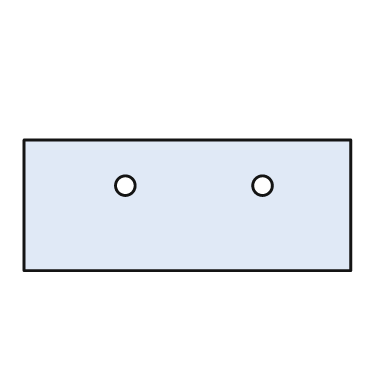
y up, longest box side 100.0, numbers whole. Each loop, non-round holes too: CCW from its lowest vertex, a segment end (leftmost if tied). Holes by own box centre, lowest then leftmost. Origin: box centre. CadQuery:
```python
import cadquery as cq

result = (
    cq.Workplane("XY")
    .moveTo(-50.0, -20.0)
    .lineTo(50.0, -20.0)
    .lineTo(50.0, 20.0)
    .lineTo(-50.0, 20.0)
    .close()
    .moveTo(-19.0, 6.0)
    .circle(3.0)
    .moveTo(23.0, 6.0)
    .circle(3.0)
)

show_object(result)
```